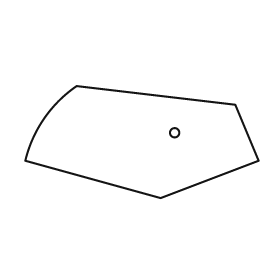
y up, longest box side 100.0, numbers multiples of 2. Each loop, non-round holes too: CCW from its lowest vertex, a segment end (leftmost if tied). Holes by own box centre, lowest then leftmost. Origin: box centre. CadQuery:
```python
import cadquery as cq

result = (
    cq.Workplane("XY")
    .moveTo(8.0, -24.0)
    .lineTo(50.0, -8.0)
    .lineTo(40.0, 16.0)
    .lineTo(-28.0, 24.0)
    .threePointArc((-42.0, 10.0), (-50.0, -8.0))
    .close()
    .moveTo(14.0, 4.0)
    .circle(2.0)
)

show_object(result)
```